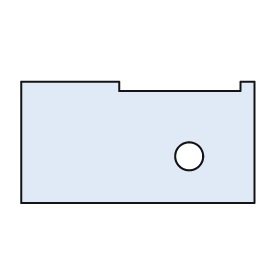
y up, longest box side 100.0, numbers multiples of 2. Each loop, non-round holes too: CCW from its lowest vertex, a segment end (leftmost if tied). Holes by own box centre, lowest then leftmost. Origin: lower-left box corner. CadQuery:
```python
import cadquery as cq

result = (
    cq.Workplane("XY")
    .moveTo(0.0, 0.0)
    .lineTo(100.0, 0.0)
    .lineTo(100.0, 52.0)
    .lineTo(94.0, 52.0)
    .lineTo(94.0, 48.0)
    .lineTo(42.0, 48.0)
    .lineTo(42.0, 52.0)
    .lineTo(0.0, 52.0)
    .close()
    .moveTo(72.0, 20.0)
    .circle(6.0)
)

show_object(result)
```